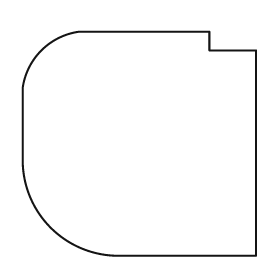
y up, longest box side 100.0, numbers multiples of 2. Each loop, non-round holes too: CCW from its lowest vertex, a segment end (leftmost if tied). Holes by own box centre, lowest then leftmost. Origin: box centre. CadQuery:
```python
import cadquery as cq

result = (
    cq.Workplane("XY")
    .moveTo(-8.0, -48.0)
    .lineTo(50.0, -48.0)
    .lineTo(50.0, 40.0)
    .lineTo(30.0, 40.0)
    .lineTo(30.0, 48.0)
    .lineTo(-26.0, 48.0)
    .threePointArc((-42.0, 40.0), (-50.0, 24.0))
    .lineTo(-50.0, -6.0)
    .threePointArc((-38.0, -36.0), (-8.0, -48.0))
    .close()
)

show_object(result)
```